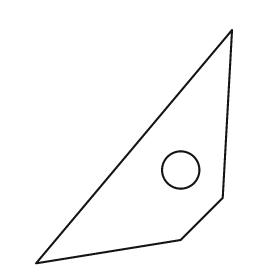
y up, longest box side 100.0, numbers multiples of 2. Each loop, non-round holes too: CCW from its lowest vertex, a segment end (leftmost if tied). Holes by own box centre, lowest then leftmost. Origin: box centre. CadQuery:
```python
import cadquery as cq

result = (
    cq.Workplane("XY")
    .moveTo(-42.0, -50.0)
    .lineTo(20.0, -40.0)
    .lineTo(38.0, -22.0)
    .lineTo(42.0, 50.0)
    .close()
    .moveTo(20.0, -10.0)
    .circle(8.0)
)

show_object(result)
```